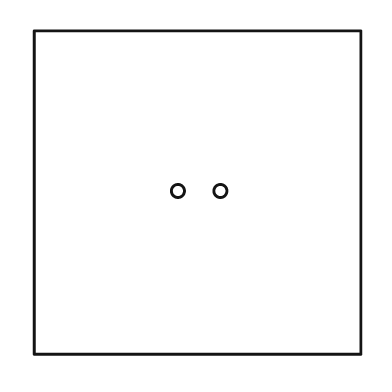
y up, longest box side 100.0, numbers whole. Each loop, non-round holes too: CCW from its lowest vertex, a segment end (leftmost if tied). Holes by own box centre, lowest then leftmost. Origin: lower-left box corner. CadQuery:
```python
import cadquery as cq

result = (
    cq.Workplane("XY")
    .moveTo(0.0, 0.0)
    .lineTo(100.0, 0.0)
    .lineTo(100.0, 99.0)
    .lineTo(0.0, 99.0)
    .close()
    .moveTo(44.0, 50.0)
    .circle(2.0)
    .moveTo(57.0, 50.0)
    .circle(2.0)
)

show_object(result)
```